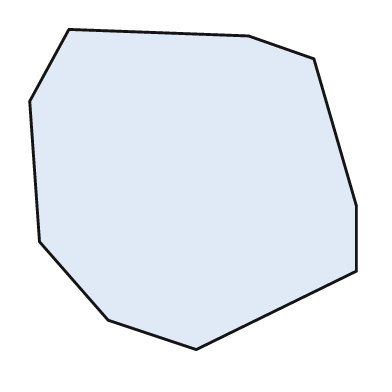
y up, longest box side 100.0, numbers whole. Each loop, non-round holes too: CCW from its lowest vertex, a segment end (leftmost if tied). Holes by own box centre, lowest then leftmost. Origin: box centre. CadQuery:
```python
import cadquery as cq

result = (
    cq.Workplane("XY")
    .moveTo(1.0, -49.0)
    .lineTo(50.0, -25.0)
    .lineTo(50.0, -5.0)
    .lineTo(37.0, 40.0)
    .lineTo(17.0, 47.0)
    .lineTo(-38.0, 49.0)
    .lineTo(-50.0, 27.0)
    .lineTo(-47.0, -16.0)
    .lineTo(-26.0, -40.0)
    .close()
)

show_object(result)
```